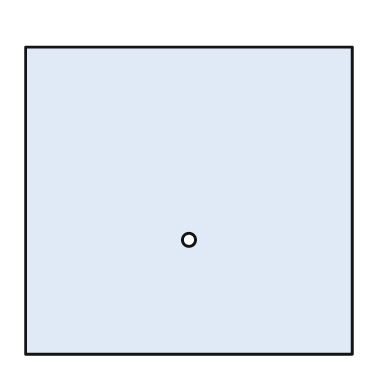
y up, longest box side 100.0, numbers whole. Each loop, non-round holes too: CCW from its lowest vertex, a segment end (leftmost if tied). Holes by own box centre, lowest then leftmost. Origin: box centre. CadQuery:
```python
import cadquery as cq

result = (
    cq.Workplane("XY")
    .moveTo(-50.0, -47.0)
    .lineTo(50.0, -47.0)
    .lineTo(50.0, 47.0)
    .lineTo(-50.0, 47.0)
    .close()
    .moveTo(0.0, -12.0)
    .circle(2.0)
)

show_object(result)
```